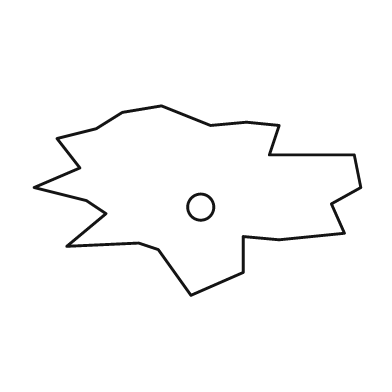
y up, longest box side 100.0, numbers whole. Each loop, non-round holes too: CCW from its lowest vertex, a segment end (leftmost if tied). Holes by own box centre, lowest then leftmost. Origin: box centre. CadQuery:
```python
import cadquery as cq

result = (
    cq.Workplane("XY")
    .moveTo(-2.0, -29.0)
    .lineTo(14.0, -22.0)
    .lineTo(14.0, -11.0)
    .lineTo(25.0, -12.0)
    .lineTo(45.0, -10.0)
    .lineTo(41.0, -1.0)
    .lineTo(50.0, 4.0)
    .lineTo(48.0, 14.0)
    .lineTo(22.0, 14.0)
    .lineTo(25.0, 23.0)
    .lineTo(15.0, 24.0)
    .lineTo(4.0, 23.0)
    .lineTo(-11.0, 29.0)
    .lineTo(-23.0, 27.0)
    .lineTo(-31.0, 22.0)
    .lineTo(-43.0, 19.0)
    .lineTo(-36.0, 10.0)
    .lineTo(-50.0, 4.0)
    .lineTo(-34.0, 0.0)
    .lineTo(-28.0, -4.0)
    .lineTo(-40.0, -14.0)
    .lineTo(-18.0, -13.0)
    .lineTo(-12.0, -15.0)
    .close()
    .moveTo(1.0, -2.0)
    .circle(4.0)
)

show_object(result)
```